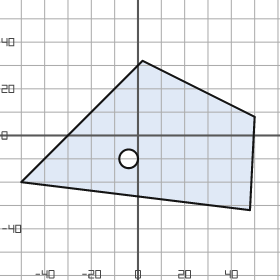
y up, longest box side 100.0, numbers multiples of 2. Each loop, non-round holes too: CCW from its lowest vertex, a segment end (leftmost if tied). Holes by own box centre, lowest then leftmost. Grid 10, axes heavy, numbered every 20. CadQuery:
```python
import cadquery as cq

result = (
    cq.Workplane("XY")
    .moveTo(48.0, -32.0)
    .lineTo(50.0, 8.0)
    .lineTo(2.0, 32.0)
    .lineTo(-50.0, -20.0)
    .close()
    .moveTo(-4.0, -10.0)
    .circle(4.0)
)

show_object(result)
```